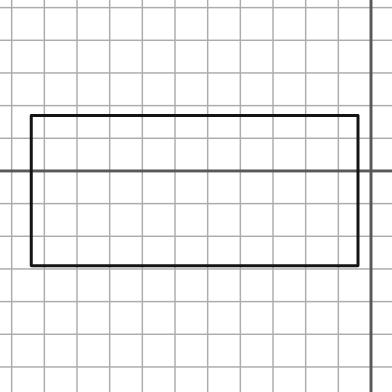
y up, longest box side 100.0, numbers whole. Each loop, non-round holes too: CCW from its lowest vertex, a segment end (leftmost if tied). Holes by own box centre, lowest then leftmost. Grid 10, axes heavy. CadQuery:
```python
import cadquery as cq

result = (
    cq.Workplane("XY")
    .moveTo(-104.0, -29.0)
    .lineTo(-4.0, -29.0)
    .lineTo(-4.0, 17.0)
    .lineTo(-104.0, 17.0)
    .close()
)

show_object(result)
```